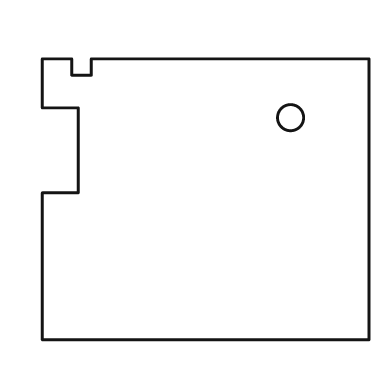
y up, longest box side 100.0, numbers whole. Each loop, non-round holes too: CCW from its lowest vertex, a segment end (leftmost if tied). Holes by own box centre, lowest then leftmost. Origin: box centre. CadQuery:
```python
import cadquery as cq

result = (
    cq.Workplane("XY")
    .moveTo(-50.0, -43.0)
    .lineTo(50.0, -43.0)
    .lineTo(50.0, 43.0)
    .lineTo(-35.0, 43.0)
    .lineTo(-35.0, 38.0)
    .lineTo(-41.0, 38.0)
    .lineTo(-41.0, 43.0)
    .lineTo(-50.0, 43.0)
    .lineTo(-50.0, 28.0)
    .lineTo(-39.0, 28.0)
    .lineTo(-39.0, 2.0)
    .lineTo(-50.0, 2.0)
    .close()
    .moveTo(26.0, 25.0)
    .circle(4.0)
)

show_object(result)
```